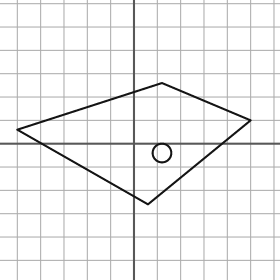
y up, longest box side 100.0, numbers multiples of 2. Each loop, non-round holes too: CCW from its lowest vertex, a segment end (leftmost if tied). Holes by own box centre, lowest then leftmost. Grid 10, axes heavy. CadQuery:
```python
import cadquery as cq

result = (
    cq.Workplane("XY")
    .moveTo(6.0, -26.0)
    .lineTo(50.0, 10.0)
    .lineTo(12.0, 26.0)
    .lineTo(-50.0, 6.0)
    .close()
    .moveTo(12.0, -4.0)
    .circle(4.0)
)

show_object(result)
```